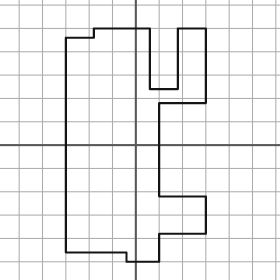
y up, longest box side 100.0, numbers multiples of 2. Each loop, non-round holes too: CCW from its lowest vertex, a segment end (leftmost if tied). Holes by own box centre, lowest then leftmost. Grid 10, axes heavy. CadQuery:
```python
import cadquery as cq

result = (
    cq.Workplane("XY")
    .moveTo(-4.0, -50.0)
    .lineTo(10.0, -50.0)
    .lineTo(10.0, -38.0)
    .lineTo(30.0, -38.0)
    .lineTo(30.0, -22.0)
    .lineTo(10.0, -22.0)
    .lineTo(10.0, 18.0)
    .lineTo(30.0, 18.0)
    .lineTo(30.0, 50.0)
    .lineTo(18.0, 50.0)
    .lineTo(18.0, 24.0)
    .lineTo(6.0, 24.0)
    .lineTo(6.0, 50.0)
    .lineTo(-18.0, 50.0)
    .lineTo(-18.0, 46.0)
    .lineTo(-30.0, 46.0)
    .lineTo(-30.0, -46.0)
    .lineTo(-4.0, -46.0)
    .close()
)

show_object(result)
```